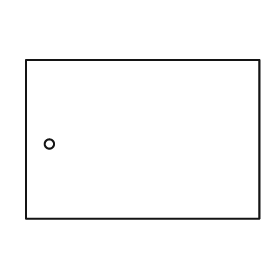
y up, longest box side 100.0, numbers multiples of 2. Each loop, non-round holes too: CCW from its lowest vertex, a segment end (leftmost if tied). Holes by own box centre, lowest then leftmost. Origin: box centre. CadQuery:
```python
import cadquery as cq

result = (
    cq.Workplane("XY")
    .moveTo(-50.0, -34.0)
    .lineTo(50.0, -34.0)
    .lineTo(50.0, 34.0)
    .lineTo(-50.0, 34.0)
    .close()
    .moveTo(-40.0, -2.0)
    .circle(2.0)
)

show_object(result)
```